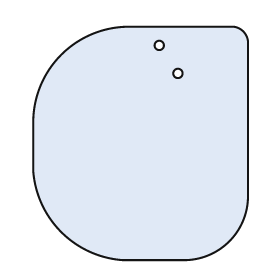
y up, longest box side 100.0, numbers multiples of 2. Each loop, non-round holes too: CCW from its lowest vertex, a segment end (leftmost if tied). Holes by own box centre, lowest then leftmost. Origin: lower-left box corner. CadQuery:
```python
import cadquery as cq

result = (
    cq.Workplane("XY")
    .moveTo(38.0, 0.0)
    .lineTo(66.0, 0.0)
    .threePointArc((84.0, 8.0), (92.0, 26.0))
    .lineTo(92.0, 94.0)
    .threePointArc((90.0, 98.0), (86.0, 100.0))
    .lineTo(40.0, 100.0)
    .threePointArc((12.0, 88.0), (0.0, 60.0))
    .lineTo(0.0, 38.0)
    .threePointArc((12.0, 12.0), (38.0, 0.0))
    .close()
    .moveTo(62.0, 80.0)
    .circle(2.0)
    .moveTo(54.0, 92.0)
    .circle(2.0)
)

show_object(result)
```